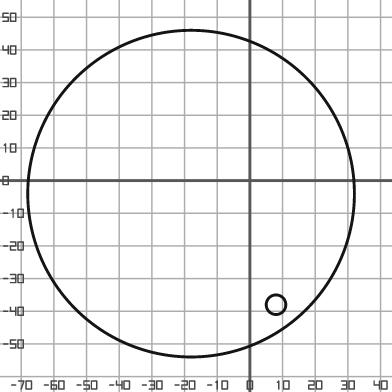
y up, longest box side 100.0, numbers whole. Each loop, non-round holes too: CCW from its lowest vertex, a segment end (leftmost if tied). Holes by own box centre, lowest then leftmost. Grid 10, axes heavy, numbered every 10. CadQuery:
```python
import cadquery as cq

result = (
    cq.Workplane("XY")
    .moveTo(-18.0, -4.0)
    .circle(50.0)
    .moveTo(8.0, -38.0)
    .circle(3.0)
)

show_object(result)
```